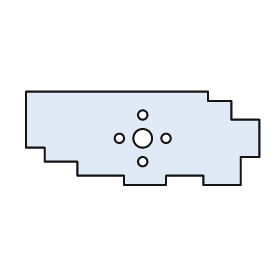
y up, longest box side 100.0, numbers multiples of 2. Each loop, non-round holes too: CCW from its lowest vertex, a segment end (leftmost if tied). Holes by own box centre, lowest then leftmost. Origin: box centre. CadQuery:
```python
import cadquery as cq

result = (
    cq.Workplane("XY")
    .moveTo(-8.0, -20.0)
    .lineTo(10.0, -20.0)
    .lineTo(10.0, -16.0)
    .lineTo(26.0, -16.0)
    .lineTo(26.0, -20.0)
    .lineTo(42.0, -20.0)
    .lineTo(42.0, -8.0)
    .lineTo(50.0, -8.0)
    .lineTo(50.0, 8.0)
    .lineTo(38.0, 8.0)
    .lineTo(38.0, 16.0)
    .lineTo(28.0, 16.0)
    .lineTo(28.0, 20.0)
    .lineTo(-50.0, 20.0)
    .lineTo(-50.0, -4.0)
    .lineTo(-42.0, -4.0)
    .lineTo(-42.0, -10.0)
    .lineTo(-28.0, -10.0)
    .lineTo(-28.0, -16.0)
    .lineTo(-8.0, -16.0)
    .close()
    .moveTo(0.0, -10.0)
    .circle(2.0)
    .moveTo(-10.0, 0.0)
    .circle(2.0)
    .moveTo(0.0, 0.0)
    .circle(4.0)
    .moveTo(10.0, 0.0)
    .circle(2.0)
    .moveTo(0.0, 10.0)
    .circle(2.0)
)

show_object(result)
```